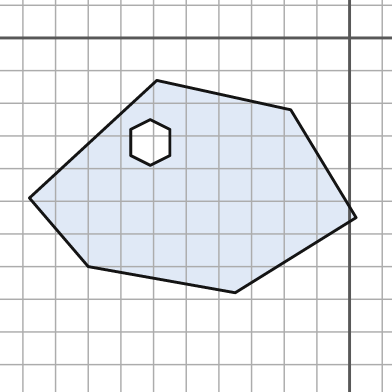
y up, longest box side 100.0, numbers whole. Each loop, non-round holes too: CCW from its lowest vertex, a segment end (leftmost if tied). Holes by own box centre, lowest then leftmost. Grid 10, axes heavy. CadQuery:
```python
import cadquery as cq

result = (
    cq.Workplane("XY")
    .moveTo(-35.0, -78.0)
    .lineTo(2.0, -55.0)
    .lineTo(-18.0, -22.0)
    .lineTo(-59.0, -13.0)
    .lineTo(-98.0, -49.0)
    .lineTo(-80.0, -70.0)
    .close()
    .moveTo(-61.0, -39.0)
    .lineTo(-55.0, -36.0)
    .lineTo(-55.0, -28.0)
    .lineTo(-61.0, -25.0)
    .lineTo(-67.0, -28.0)
    .lineTo(-67.0, -36.0)
    .close()
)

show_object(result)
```